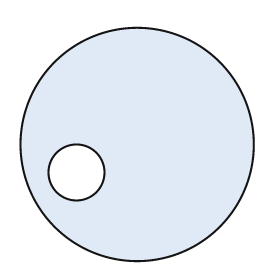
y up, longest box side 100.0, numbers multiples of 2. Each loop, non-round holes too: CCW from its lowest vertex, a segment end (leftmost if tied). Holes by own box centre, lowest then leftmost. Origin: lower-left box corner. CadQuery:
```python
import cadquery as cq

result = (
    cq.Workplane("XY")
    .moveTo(50.0, 50.0)
    .circle(50.0)
    .moveTo(24.0, 38.0)
    .circle(12.0)
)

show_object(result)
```